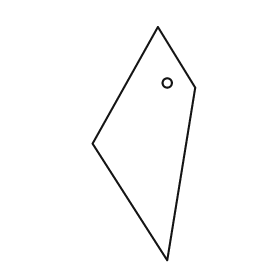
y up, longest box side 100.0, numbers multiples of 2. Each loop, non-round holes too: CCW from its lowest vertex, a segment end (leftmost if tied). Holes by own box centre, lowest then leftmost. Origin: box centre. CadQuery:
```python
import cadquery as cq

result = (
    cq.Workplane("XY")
    .moveTo(10.0, -50.0)
    .lineTo(22.0, 24.0)
    .lineTo(6.0, 50.0)
    .lineTo(-22.0, 0.0)
    .close()
    .moveTo(10.0, 26.0)
    .circle(2.0)
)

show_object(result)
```